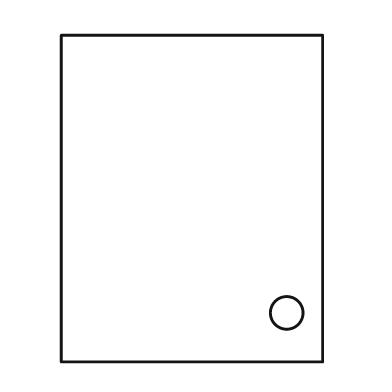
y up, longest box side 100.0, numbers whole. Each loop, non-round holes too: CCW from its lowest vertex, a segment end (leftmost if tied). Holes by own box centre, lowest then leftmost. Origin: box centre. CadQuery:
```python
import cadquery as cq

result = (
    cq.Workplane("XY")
    .moveTo(-40.0, -50.0)
    .lineTo(40.0, -50.0)
    .lineTo(40.0, 50.0)
    .lineTo(-40.0, 50.0)
    .close()
    .moveTo(29.0, -35.0)
    .circle(5.0)
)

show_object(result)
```